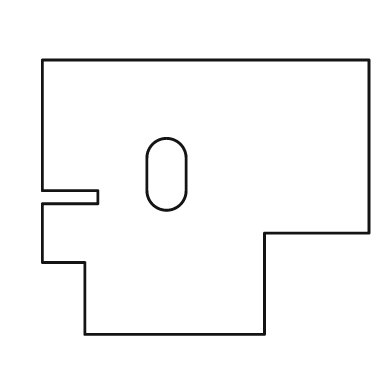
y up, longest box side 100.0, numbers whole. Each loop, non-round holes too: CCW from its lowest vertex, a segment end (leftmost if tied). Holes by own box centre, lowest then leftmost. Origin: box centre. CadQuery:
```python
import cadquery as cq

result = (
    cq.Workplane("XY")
    .moveTo(-37.0, -42.0)
    .lineTo(18.0, -42.0)
    .lineTo(18.0, -11.0)
    .lineTo(50.0, -11.0)
    .lineTo(50.0, 42.0)
    .lineTo(-50.0, 42.0)
    .lineTo(-50.0, 2.0)
    .lineTo(-33.0, 2.0)
    .lineTo(-33.0, -2.0)
    .lineTo(-50.0, -2.0)
    .lineTo(-50.0, -20.0)
    .lineTo(-37.0, -20.0)
    .close()
    .moveTo(-18.0, 2.0)
    .threePointArc((-12.0, -4.0), (-6.0, 2.0))
    .lineTo(-6.0, 12.0)
    .threePointArc((-12.0, 18.0), (-18.0, 12.0))
    .close()
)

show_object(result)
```